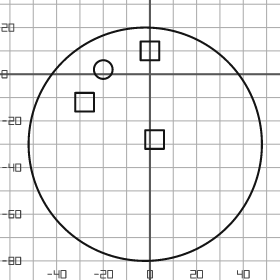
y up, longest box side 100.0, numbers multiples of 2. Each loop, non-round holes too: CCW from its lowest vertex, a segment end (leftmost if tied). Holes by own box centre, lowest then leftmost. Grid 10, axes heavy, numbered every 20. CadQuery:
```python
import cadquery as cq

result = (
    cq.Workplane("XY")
    .moveTo(-2.0, -30.0)
    .circle(50.0)
    .moveTo(-2.0, -32.0)
    .lineTo(6.0, -32.0)
    .lineTo(6.0, -24.0)
    .lineTo(-2.0, -24.0)
    .close()
    .moveTo(-32.0, -16.0)
    .lineTo(-24.0, -16.0)
    .lineTo(-24.0, -8.0)
    .lineTo(-32.0, -8.0)
    .close()
    .moveTo(-20.0, 2.0)
    .circle(4.0)
    .moveTo(-4.0, 6.0)
    .lineTo(4.0, 6.0)
    .lineTo(4.0, 14.0)
    .lineTo(-4.0, 14.0)
    .close()
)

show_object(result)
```